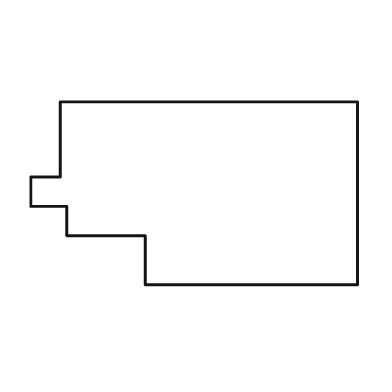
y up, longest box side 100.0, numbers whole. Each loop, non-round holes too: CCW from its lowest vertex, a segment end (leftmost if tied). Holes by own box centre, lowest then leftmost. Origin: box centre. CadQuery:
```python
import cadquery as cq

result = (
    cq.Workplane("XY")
    .moveTo(-15.0, -28.0)
    .lineTo(50.0, -28.0)
    .lineTo(50.0, 28.0)
    .lineTo(-41.0, 28.0)
    .lineTo(-41.0, 5.0)
    .lineTo(-50.0, 5.0)
    .lineTo(-50.0, -4.0)
    .lineTo(-39.0, -4.0)
    .lineTo(-39.0, -13.0)
    .lineTo(-15.0, -13.0)
    .close()
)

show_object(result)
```